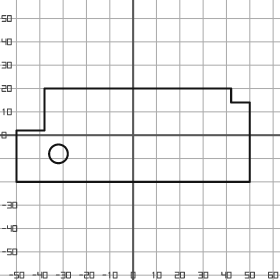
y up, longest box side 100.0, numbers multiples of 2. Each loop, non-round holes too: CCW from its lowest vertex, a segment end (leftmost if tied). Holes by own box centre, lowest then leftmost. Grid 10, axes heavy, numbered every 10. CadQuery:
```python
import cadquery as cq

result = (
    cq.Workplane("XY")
    .moveTo(-50.0, -20.0)
    .lineTo(50.0, -20.0)
    .lineTo(50.0, 14.0)
    .lineTo(42.0, 14.0)
    .lineTo(42.0, 20.0)
    .lineTo(-38.0, 20.0)
    .lineTo(-38.0, 2.0)
    .lineTo(-50.0, 2.0)
    .close()
    .moveTo(-32.0, -8.0)
    .circle(4.0)
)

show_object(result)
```